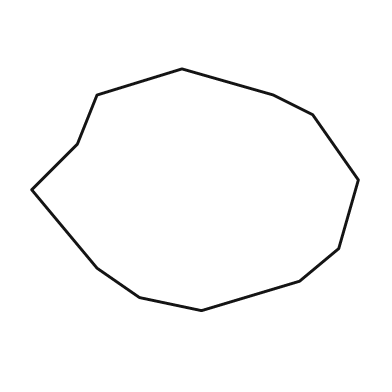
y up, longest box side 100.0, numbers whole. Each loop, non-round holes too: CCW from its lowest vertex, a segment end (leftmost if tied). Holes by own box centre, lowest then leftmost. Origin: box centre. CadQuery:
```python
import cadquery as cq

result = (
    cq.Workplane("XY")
    .moveTo(2.0, -37.0)
    .lineTo(32.0, -28.0)
    .lineTo(44.0, -18.0)
    .lineTo(50.0, 3.0)
    .lineTo(36.0, 23.0)
    .lineTo(24.0, 29.0)
    .lineTo(-4.0, 37.0)
    .lineTo(-30.0, 29.0)
    .lineTo(-36.0, 14.0)
    .lineTo(-50.0, 0.0)
    .lineTo(-30.0, -24.0)
    .lineTo(-17.0, -33.0)
    .close()
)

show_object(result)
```